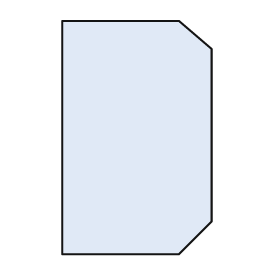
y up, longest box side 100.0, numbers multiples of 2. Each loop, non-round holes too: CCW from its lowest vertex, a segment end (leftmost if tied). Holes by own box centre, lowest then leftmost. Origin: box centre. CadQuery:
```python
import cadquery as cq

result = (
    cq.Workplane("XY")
    .moveTo(-32.0, -50.0)
    .lineTo(18.0, -50.0)
    .lineTo(32.0, -36.0)
    .lineTo(32.0, 38.0)
    .lineTo(18.0, 50.0)
    .lineTo(-32.0, 50.0)
    .close()
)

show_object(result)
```